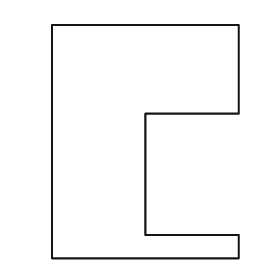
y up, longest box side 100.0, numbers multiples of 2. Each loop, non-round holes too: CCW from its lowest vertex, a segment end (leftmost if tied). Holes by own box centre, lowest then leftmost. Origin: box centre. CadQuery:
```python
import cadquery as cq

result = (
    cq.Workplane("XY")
    .moveTo(-40.0, -50.0)
    .lineTo(40.0, -50.0)
    .lineTo(40.0, -40.0)
    .lineTo(0.0, -40.0)
    .lineTo(0.0, 12.0)
    .lineTo(40.0, 12.0)
    .lineTo(40.0, 50.0)
    .lineTo(-40.0, 50.0)
    .close()
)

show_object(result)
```